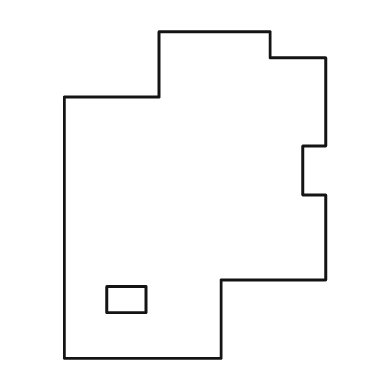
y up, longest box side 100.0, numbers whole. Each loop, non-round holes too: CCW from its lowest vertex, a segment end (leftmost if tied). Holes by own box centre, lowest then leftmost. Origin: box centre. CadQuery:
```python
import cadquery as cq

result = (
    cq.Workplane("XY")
    .moveTo(-40.0, -50.0)
    .lineTo(8.0, -50.0)
    .lineTo(8.0, -26.0)
    .lineTo(40.0, -26.0)
    .lineTo(40.0, 0.0)
    .lineTo(33.0, 0.0)
    .lineTo(33.0, 15.0)
    .lineTo(40.0, 15.0)
    .lineTo(40.0, 42.0)
    .lineTo(23.0, 42.0)
    .lineTo(23.0, 50.0)
    .lineTo(-11.0, 50.0)
    .lineTo(-11.0, 30.0)
    .lineTo(-40.0, 30.0)
    .close()
    .moveTo(-27.0, -36.0)
    .lineTo(-15.0, -36.0)
    .lineTo(-15.0, -28.0)
    .lineTo(-27.0, -28.0)
    .close()
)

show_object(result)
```